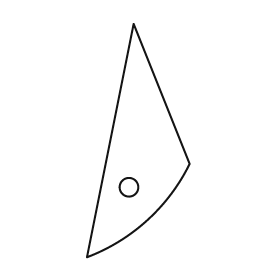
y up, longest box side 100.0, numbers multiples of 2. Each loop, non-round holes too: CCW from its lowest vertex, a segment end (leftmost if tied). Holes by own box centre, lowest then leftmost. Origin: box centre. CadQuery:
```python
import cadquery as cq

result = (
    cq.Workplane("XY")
    .moveTo(-22.0, -50.0)
    .threePointArc((4.0, -34.0), (22.0, -10.0))
    .lineTo(-2.0, 50.0)
    .close()
    .moveTo(-4.0, -20.0)
    .circle(4.0)
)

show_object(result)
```